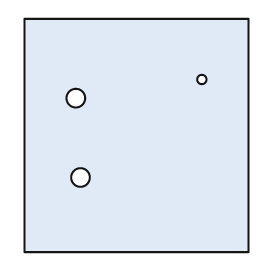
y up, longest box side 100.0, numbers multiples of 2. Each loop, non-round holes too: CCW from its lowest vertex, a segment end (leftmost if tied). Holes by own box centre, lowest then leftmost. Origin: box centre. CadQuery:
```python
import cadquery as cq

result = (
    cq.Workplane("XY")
    .moveTo(-48.0, -50.0)
    .lineTo(48.0, -50.0)
    .lineTo(48.0, 50.0)
    .lineTo(-48.0, 50.0)
    .close()
    .moveTo(-24.0, -18.0)
    .circle(4.0)
    .moveTo(-26.0, 16.0)
    .circle(4.0)
    .moveTo(28.0, 24.0)
    .circle(2.0)
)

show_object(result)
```